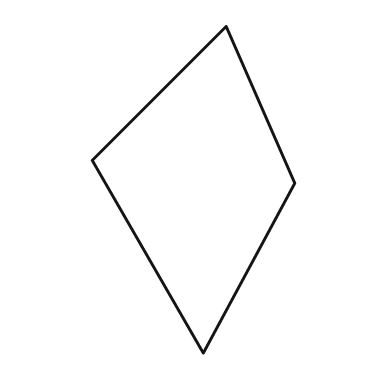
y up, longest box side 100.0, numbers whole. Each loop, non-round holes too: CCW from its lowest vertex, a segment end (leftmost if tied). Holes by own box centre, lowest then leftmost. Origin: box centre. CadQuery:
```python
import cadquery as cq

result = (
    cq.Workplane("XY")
    .moveTo(3.0, -50.0)
    .lineTo(31.0, 2.0)
    .lineTo(10.0, 50.0)
    .lineTo(-31.0, 9.0)
    .close()
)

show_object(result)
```